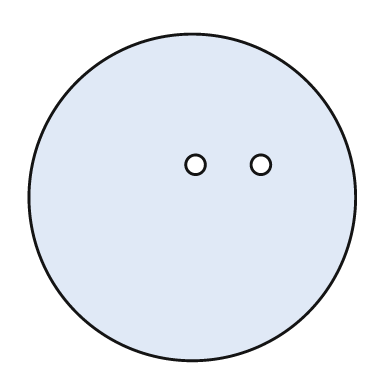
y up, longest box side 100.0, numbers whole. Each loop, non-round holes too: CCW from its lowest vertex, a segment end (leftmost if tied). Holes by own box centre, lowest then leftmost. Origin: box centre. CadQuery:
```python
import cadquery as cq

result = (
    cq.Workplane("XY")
    .moveTo(0.0, 0.0)
    .circle(50.0)
    .moveTo(1.0, 10.0)
    .circle(3.0)
    .moveTo(21.0, 10.0)
    .circle(3.0)
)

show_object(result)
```